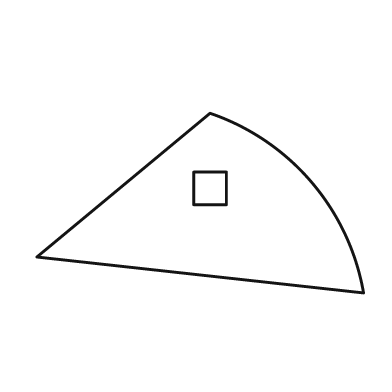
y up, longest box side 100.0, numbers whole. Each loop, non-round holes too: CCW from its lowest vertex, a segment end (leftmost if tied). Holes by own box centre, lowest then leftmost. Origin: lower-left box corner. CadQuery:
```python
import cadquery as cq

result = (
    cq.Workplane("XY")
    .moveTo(100.0, 0.0)
    .threePointArc((84.0, 34.0), (53.0, 55.0))
    .lineTo(0.0, 11.0)
    .close()
    .moveTo(48.0, 27.0)
    .lineTo(58.0, 27.0)
    .lineTo(58.0, 37.0)
    .lineTo(48.0, 37.0)
    .close()
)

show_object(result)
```